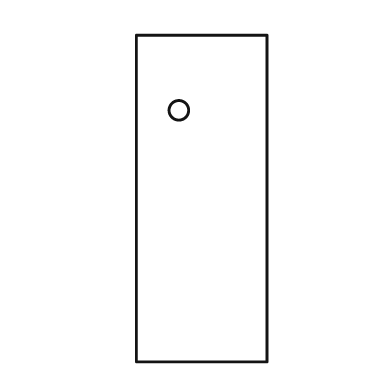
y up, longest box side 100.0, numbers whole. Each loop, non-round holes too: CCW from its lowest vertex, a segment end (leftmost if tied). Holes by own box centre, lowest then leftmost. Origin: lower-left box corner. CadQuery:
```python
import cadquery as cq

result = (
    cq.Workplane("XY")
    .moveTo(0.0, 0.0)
    .lineTo(40.0, 0.0)
    .lineTo(40.0, 100.0)
    .lineTo(0.0, 100.0)
    .close()
    .moveTo(13.0, 77.0)
    .circle(3.0)
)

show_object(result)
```